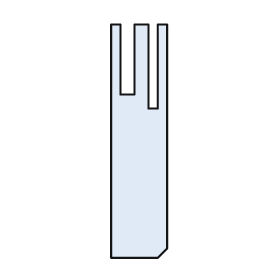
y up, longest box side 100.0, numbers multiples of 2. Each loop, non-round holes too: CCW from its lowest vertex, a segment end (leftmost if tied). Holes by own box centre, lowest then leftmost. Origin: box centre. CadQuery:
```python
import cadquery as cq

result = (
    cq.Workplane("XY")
    .moveTo(-12.0, -50.0)
    .lineTo(8.0, -50.0)
    .lineTo(12.0, -46.0)
    .lineTo(12.0, 50.0)
    .lineTo(8.0, 50.0)
    .lineTo(8.0, 14.0)
    .lineTo(4.0, 14.0)
    .lineTo(4.0, 50.0)
    .lineTo(-2.0, 50.0)
    .lineTo(-2.0, 20.0)
    .lineTo(-8.0, 20.0)
    .lineTo(-8.0, 50.0)
    .lineTo(-12.0, 50.0)
    .close()
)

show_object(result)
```